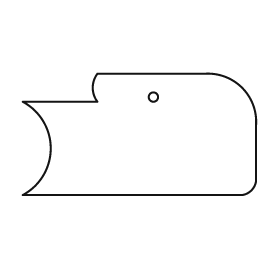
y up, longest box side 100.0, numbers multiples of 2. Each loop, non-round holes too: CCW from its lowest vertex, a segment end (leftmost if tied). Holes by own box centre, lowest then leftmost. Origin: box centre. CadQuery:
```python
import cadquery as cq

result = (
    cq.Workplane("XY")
    .moveTo(-50.0, -26.0)
    .lineTo(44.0, -26.0)
    .threePointArc((48.0, -24.0), (50.0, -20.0))
    .lineTo(50.0, 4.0)
    .threePointArc((44.0, 20.0), (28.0, 26.0))
    .lineTo(-18.0, 26.0)
    .threePointArc((-20.0, 20.0), (-18.0, 14.0))
    .lineTo(-50.0, 14.0)
    .threePointArc((-38.0, -6.0), (-50.0, -26.0))
    .close()
    .moveTo(6.0, 16.0)
    .circle(2.0)
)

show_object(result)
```